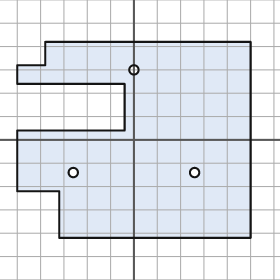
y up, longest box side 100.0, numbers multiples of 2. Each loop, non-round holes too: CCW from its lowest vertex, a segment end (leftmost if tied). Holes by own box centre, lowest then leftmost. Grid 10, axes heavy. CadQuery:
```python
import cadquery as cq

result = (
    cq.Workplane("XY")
    .moveTo(-32.0, -42.0)
    .lineTo(50.0, -42.0)
    .lineTo(50.0, 42.0)
    .lineTo(-38.0, 42.0)
    .lineTo(-38.0, 32.0)
    .lineTo(-50.0, 32.0)
    .lineTo(-50.0, 24.0)
    .lineTo(-4.0, 24.0)
    .lineTo(-4.0, 4.0)
    .lineTo(-50.0, 4.0)
    .lineTo(-50.0, -22.0)
    .lineTo(-32.0, -22.0)
    .close()
    .moveTo(-26.0, -14.0)
    .circle(2.0)
    .moveTo(26.0, -14.0)
    .circle(2.0)
    .moveTo(0.0, 30.0)
    .circle(2.0)
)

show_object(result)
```